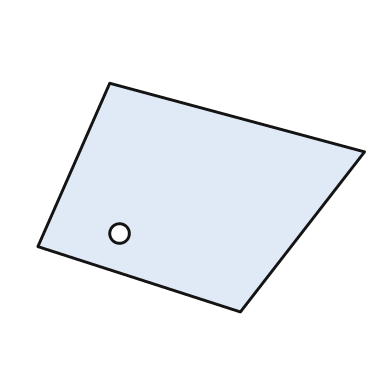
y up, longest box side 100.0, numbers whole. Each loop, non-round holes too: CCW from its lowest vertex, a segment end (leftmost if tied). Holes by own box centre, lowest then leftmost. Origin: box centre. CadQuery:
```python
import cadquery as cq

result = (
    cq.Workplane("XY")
    .moveTo(12.0, -35.0)
    .lineTo(50.0, 14.0)
    .lineTo(-28.0, 35.0)
    .lineTo(-50.0, -15.0)
    .close()
    .moveTo(-25.0, -11.0)
    .circle(3.0)
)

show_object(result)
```